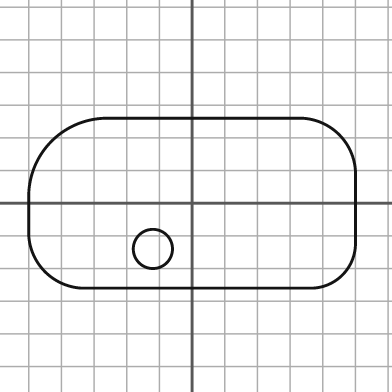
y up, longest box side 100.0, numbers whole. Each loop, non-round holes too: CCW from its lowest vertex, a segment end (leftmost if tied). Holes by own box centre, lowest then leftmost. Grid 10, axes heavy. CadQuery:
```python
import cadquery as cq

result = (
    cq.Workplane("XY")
    .moveTo(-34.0, -26.0)
    .lineTo(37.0, -26.0)
    .threePointArc((46.0, -22.0), (50.0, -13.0))
    .lineTo(50.0, 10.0)
    .threePointArc((45.0, 21.0), (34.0, 26.0))
    .lineTo(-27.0, 26.0)
    .threePointArc((-43.0, 19.0), (-50.0, 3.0))
    .lineTo(-50.0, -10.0)
    .threePointArc((-45.0, -21.0), (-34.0, -26.0))
    .close()
    .moveTo(-12.0, -14.0)
    .circle(6.0)
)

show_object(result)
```